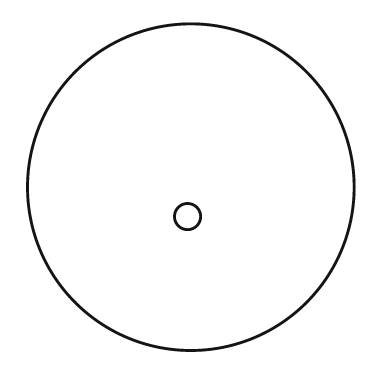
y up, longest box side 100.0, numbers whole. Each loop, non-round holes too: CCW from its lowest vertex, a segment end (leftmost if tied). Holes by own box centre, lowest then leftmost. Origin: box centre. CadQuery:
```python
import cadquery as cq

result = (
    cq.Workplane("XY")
    .moveTo(0.0, 0.0)
    .circle(50.0)
    .moveTo(-1.0, -9.0)
    .circle(4.0)
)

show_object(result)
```